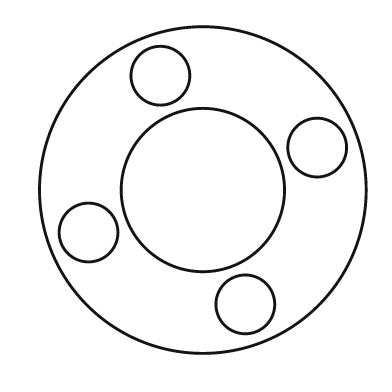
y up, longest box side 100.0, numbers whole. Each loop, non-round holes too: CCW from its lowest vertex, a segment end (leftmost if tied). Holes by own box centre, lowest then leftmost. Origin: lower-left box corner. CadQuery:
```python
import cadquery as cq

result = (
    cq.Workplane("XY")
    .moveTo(50.0, 50.0)
    .circle(50.0)
    .moveTo(63.0, 15.0)
    .circle(9.0)
    .moveTo(15.0, 37.0)
    .circle(9.0)
    .moveTo(50.0, 50.0)
    .circle(25.0)
    .moveTo(85.0, 63.0)
    .circle(9.0)
    .moveTo(37.0, 85.0)
    .circle(9.0)
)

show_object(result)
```